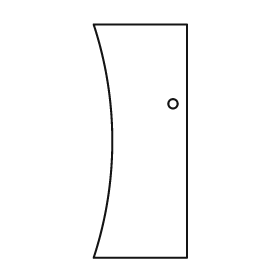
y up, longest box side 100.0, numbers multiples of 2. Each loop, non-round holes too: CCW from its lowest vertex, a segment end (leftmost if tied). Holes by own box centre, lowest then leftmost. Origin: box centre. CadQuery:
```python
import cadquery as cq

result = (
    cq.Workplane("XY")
    .moveTo(-20.0, -50.0)
    .lineTo(20.0, -50.0)
    .lineTo(20.0, 50.0)
    .lineTo(-20.0, 50.0)
    .threePointArc((-12.0, 0.0), (-20.0, -50.0))
    .close()
    .moveTo(14.0, 16.0)
    .circle(2.0)
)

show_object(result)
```